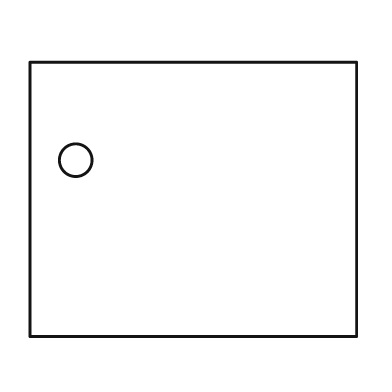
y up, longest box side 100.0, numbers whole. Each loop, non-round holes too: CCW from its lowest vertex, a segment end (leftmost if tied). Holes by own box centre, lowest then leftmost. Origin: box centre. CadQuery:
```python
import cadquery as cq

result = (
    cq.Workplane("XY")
    .moveTo(-50.0, -42.0)
    .lineTo(50.0, -42.0)
    .lineTo(50.0, 42.0)
    .lineTo(-50.0, 42.0)
    .close()
    .moveTo(-36.0, 12.0)
    .circle(5.0)
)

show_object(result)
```